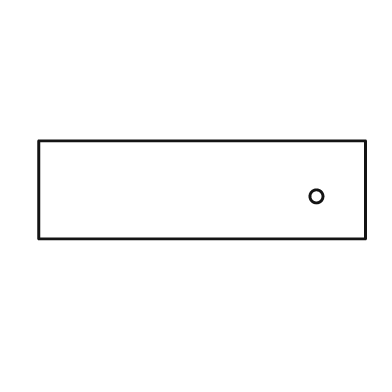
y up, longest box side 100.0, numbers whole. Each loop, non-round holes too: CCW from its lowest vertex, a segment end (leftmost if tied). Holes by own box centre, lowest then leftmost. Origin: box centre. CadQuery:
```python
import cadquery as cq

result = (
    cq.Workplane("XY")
    .moveTo(-50.0, -15.0)
    .lineTo(50.0, -15.0)
    .lineTo(50.0, 15.0)
    .lineTo(-50.0, 15.0)
    .close()
    .moveTo(35.0, -2.0)
    .circle(2.0)
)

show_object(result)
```